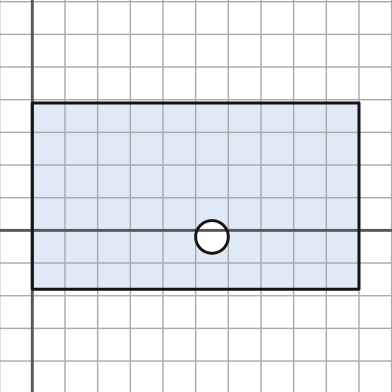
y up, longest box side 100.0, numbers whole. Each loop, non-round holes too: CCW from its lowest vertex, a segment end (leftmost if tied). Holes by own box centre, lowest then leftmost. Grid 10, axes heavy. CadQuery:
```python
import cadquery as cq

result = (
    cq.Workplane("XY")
    .moveTo(0.0, -18.0)
    .lineTo(100.0, -18.0)
    .lineTo(100.0, 39.0)
    .lineTo(0.0, 39.0)
    .close()
    .moveTo(55.0, -2.0)
    .circle(5.0)
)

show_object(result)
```